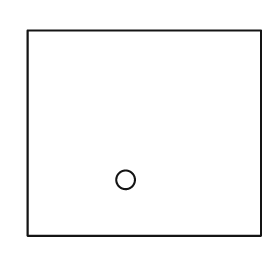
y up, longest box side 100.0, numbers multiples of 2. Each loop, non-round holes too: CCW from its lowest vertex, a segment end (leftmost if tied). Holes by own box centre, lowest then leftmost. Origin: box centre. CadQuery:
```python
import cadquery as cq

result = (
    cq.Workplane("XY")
    .moveTo(-50.0, -44.0)
    .lineTo(50.0, -44.0)
    .lineTo(50.0, 44.0)
    .lineTo(-50.0, 44.0)
    .close()
    .moveTo(-8.0, -20.0)
    .circle(4.0)
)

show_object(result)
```